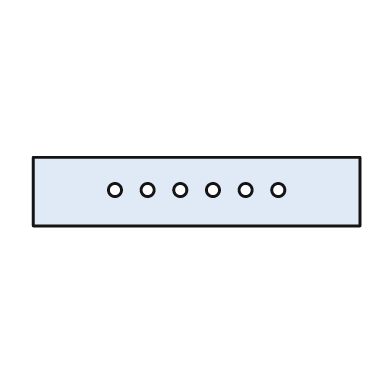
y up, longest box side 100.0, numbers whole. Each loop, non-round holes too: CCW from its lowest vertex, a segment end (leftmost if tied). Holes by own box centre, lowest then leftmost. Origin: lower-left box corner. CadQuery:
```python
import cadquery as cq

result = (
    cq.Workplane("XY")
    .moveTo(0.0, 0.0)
    .lineTo(100.0, 0.0)
    .lineTo(100.0, 21.0)
    .lineTo(0.0, 21.0)
    .close()
    .moveTo(25.0, 11.0)
    .circle(2.0)
    .moveTo(35.0, 11.0)
    .circle(2.0)
    .moveTo(45.0, 11.0)
    .circle(2.0)
    .moveTo(55.0, 11.0)
    .circle(2.0)
    .moveTo(65.0, 11.0)
    .circle(2.0)
    .moveTo(75.0, 11.0)
    .circle(2.0)
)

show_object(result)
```